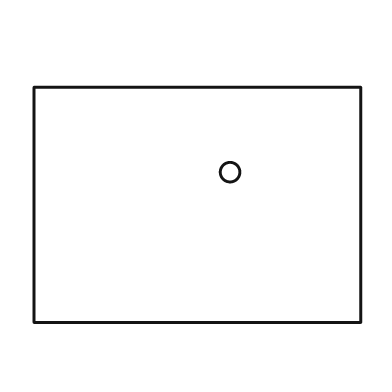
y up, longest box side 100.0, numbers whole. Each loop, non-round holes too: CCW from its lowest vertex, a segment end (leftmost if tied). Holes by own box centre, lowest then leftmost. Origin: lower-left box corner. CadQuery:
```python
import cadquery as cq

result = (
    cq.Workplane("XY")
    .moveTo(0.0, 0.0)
    .lineTo(100.0, 0.0)
    .lineTo(100.0, 72.0)
    .lineTo(0.0, 72.0)
    .close()
    .moveTo(60.0, 46.0)
    .circle(3.0)
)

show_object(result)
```